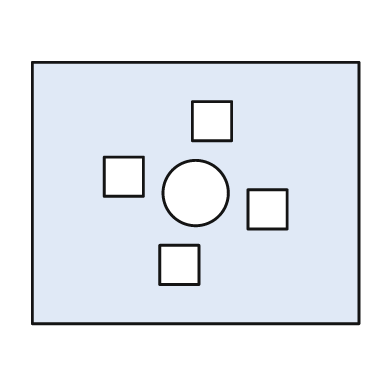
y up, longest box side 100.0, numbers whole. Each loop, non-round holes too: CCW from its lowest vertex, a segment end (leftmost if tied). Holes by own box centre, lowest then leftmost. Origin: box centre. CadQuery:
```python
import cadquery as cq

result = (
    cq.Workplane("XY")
    .moveTo(-50.0, -40.0)
    .lineTo(50.0, -40.0)
    .lineTo(50.0, 40.0)
    .lineTo(-50.0, 40.0)
    .close()
    .moveTo(-11.0, -28.0)
    .lineTo(1.0, -28.0)
    .lineTo(1.0, -16.0)
    .lineTo(-11.0, -16.0)
    .close()
    .moveTo(16.0, -11.0)
    .lineTo(28.0, -11.0)
    .lineTo(28.0, 1.0)
    .lineTo(16.0, 1.0)
    .close()
    .moveTo(0.0, 0.0)
    .circle(10.0)
    .moveTo(-28.0, -1.0)
    .lineTo(-16.0, -1.0)
    .lineTo(-16.0, 11.0)
    .lineTo(-28.0, 11.0)
    .close()
    .moveTo(-1.0, 16.0)
    .lineTo(11.0, 16.0)
    .lineTo(11.0, 28.0)
    .lineTo(-1.0, 28.0)
    .close()
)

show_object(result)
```